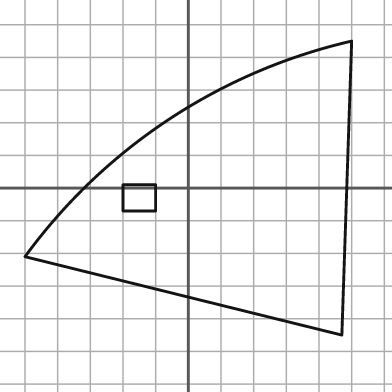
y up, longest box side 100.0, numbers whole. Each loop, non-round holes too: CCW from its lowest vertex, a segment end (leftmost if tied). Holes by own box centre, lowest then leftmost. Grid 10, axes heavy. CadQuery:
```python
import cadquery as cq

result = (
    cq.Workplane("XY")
    .moveTo(47.0, -45.0)
    .lineTo(50.0, 45.0)
    .threePointArc((-6.0, 21.0), (-50.0, -21.0))
    .close()
    .moveTo(-20.0, -7.0)
    .lineTo(-10.0, -7.0)
    .lineTo(-10.0, 1.0)
    .lineTo(-20.0, 1.0)
    .close()
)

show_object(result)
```